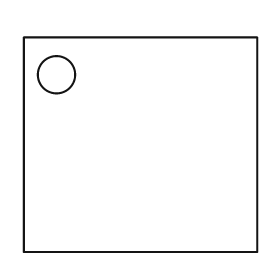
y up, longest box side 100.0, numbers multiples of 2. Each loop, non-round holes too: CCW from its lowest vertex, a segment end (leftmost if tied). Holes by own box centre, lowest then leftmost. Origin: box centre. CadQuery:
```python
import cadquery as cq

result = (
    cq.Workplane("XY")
    .moveTo(-50.0, -46.0)
    .lineTo(50.0, -46.0)
    .lineTo(50.0, 46.0)
    .lineTo(-50.0, 46.0)
    .close()
    .moveTo(-36.0, 30.0)
    .circle(8.0)
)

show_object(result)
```